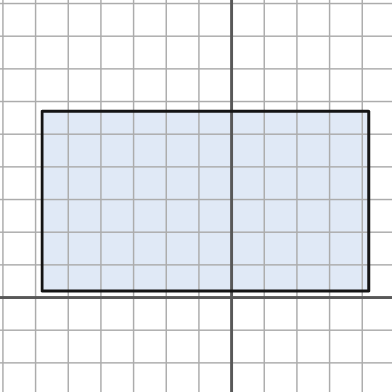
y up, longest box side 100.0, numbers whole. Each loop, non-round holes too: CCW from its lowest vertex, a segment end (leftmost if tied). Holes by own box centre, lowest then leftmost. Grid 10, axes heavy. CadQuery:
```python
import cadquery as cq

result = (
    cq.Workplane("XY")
    .moveTo(-58.0, 2.0)
    .lineTo(42.0, 2.0)
    .lineTo(42.0, 57.0)
    .lineTo(-58.0, 57.0)
    .close()
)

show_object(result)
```